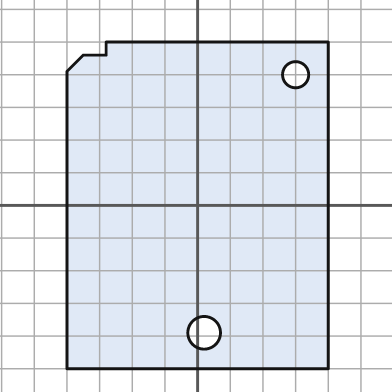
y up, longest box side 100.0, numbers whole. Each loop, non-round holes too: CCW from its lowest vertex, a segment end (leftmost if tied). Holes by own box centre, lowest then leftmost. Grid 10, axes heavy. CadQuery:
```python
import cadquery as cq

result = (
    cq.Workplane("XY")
    .moveTo(-40.0, -50.0)
    .lineTo(40.0, -50.0)
    .lineTo(40.0, 50.0)
    .lineTo(-28.0, 50.0)
    .lineTo(-28.0, 46.0)
    .lineTo(-35.0, 46.0)
    .lineTo(-40.0, 41.0)
    .close()
    .moveTo(2.0, -39.0)
    .circle(5.0)
    .moveTo(30.0, 40.0)
    .circle(4.0)
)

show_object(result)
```